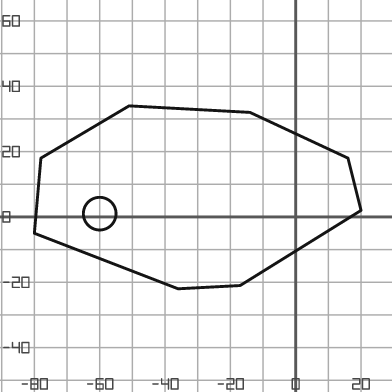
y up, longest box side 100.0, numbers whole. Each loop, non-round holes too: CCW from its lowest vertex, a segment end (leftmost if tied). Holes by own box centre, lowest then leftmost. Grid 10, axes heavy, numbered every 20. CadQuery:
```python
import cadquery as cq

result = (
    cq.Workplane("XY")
    .moveTo(-36.0, -22.0)
    .lineTo(-17.0, -21.0)
    .lineTo(20.0, 2.0)
    .lineTo(16.0, 18.0)
    .lineTo(-14.0, 32.0)
    .lineTo(-51.0, 34.0)
    .lineTo(-78.0, 18.0)
    .lineTo(-80.0, -5.0)
    .close()
    .moveTo(-60.0, 1.0)
    .circle(5.0)
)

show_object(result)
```